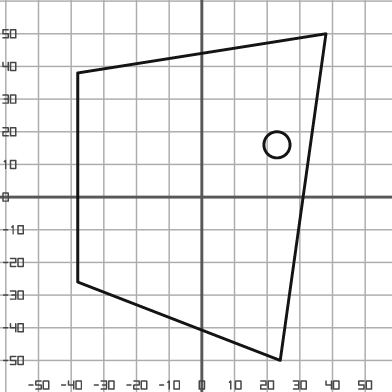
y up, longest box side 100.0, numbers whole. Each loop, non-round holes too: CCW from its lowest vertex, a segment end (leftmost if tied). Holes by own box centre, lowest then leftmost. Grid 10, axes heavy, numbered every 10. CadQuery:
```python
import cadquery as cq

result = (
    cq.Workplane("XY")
    .moveTo(24.0, -50.0)
    .lineTo(38.0, 50.0)
    .lineTo(-38.0, 38.0)
    .lineTo(-38.0, -26.0)
    .close()
    .moveTo(23.0, 16.0)
    .circle(4.0)
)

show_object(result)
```